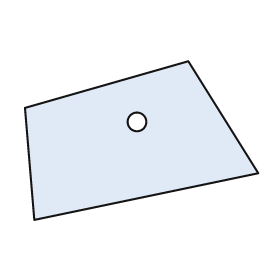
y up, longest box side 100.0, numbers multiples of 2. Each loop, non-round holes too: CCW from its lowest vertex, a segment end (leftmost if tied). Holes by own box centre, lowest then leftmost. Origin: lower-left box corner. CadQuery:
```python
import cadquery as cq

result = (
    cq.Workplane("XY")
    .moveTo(4.0, 0.0)
    .lineTo(100.0, 20.0)
    .lineTo(70.0, 68.0)
    .lineTo(0.0, 48.0)
    .close()
    .moveTo(48.0, 42.0)
    .circle(4.0)
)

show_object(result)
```